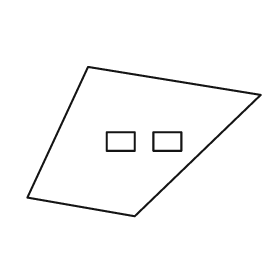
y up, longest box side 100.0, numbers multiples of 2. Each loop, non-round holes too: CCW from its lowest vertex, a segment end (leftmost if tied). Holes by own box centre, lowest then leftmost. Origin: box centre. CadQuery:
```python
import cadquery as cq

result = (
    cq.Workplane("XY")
    .moveTo(-4.0, -32.0)
    .lineTo(50.0, 20.0)
    .lineTo(-24.0, 32.0)
    .lineTo(-50.0, -24.0)
    .close()
    .moveTo(-16.0, -4.0)
    .lineTo(-4.0, -4.0)
    .lineTo(-4.0, 4.0)
    .lineTo(-16.0, 4.0)
    .close()
    .moveTo(4.0, -4.0)
    .lineTo(16.0, -4.0)
    .lineTo(16.0, 4.0)
    .lineTo(4.0, 4.0)
    .close()
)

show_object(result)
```